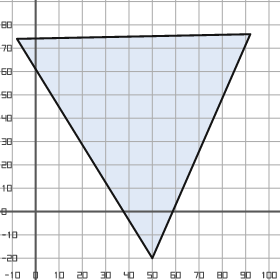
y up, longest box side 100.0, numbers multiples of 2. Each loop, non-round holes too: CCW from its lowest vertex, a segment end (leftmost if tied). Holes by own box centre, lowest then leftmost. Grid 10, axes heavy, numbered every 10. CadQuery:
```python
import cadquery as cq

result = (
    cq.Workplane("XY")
    .moveTo(50.0, -20.0)
    .lineTo(92.0, 76.0)
    .lineTo(-8.0, 74.0)
    .close()
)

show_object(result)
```